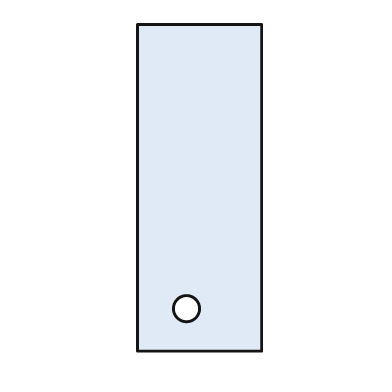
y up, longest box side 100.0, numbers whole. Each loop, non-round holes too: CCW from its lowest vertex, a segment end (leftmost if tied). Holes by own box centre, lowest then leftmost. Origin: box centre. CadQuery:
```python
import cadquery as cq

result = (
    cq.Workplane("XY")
    .moveTo(-19.0, -50.0)
    .lineTo(19.0, -50.0)
    .lineTo(19.0, 50.0)
    .lineTo(-19.0, 50.0)
    .close()
    .moveTo(-4.0, -37.0)
    .circle(4.0)
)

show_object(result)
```